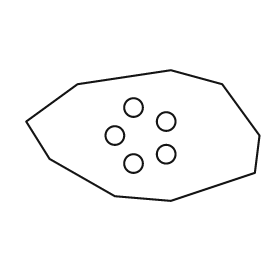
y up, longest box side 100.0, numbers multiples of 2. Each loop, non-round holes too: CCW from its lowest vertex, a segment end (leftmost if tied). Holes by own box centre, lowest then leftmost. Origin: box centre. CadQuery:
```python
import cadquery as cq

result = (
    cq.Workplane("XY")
    .moveTo(12.0, -28.0)
    .lineTo(48.0, -16.0)
    .lineTo(50.0, 0.0)
    .lineTo(34.0, 22.0)
    .lineTo(12.0, 28.0)
    .lineTo(-28.0, 22.0)
    .lineTo(-50.0, 6.0)
    .lineTo(-40.0, -10.0)
    .lineTo(-12.0, -26.0)
    .close()
    .moveTo(-4.0, -12.0)
    .circle(4.0)
    .moveTo(10.0, -8.0)
    .circle(4.0)
    .moveTo(-12.0, 0.0)
    .circle(4.0)
    .moveTo(10.0, 6.0)
    .circle(4.0)
    .moveTo(-4.0, 12.0)
    .circle(4.0)
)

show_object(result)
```